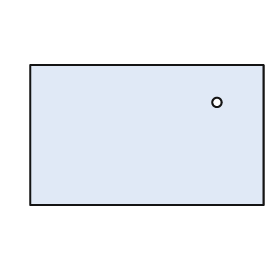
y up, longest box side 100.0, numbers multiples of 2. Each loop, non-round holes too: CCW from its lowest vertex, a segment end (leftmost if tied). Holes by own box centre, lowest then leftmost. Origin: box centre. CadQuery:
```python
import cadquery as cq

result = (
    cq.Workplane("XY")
    .moveTo(-50.0, -30.0)
    .lineTo(50.0, -30.0)
    .lineTo(50.0, 30.0)
    .lineTo(-50.0, 30.0)
    .close()
    .moveTo(30.0, 14.0)
    .circle(2.0)
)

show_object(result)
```